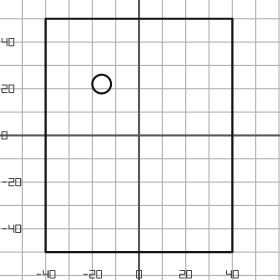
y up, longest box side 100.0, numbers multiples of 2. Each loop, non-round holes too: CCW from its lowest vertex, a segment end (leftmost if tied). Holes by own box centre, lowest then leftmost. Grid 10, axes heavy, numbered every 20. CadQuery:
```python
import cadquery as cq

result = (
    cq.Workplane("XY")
    .moveTo(-40.0, -50.0)
    .lineTo(40.0, -50.0)
    .lineTo(40.0, 50.0)
    .lineTo(-40.0, 50.0)
    .close()
    .moveTo(-16.0, 22.0)
    .circle(4.0)
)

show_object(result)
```